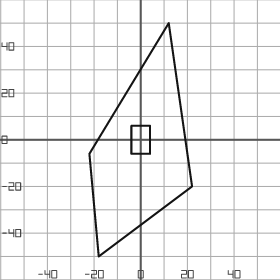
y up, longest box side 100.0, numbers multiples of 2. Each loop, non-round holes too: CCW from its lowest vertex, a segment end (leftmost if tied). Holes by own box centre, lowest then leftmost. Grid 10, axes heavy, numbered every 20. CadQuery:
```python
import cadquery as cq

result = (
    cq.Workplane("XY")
    .moveTo(-18.0, -50.0)
    .lineTo(22.0, -20.0)
    .lineTo(12.0, 50.0)
    .lineTo(-22.0, -6.0)
    .close()
    .moveTo(-4.0, -6.0)
    .lineTo(4.0, -6.0)
    .lineTo(4.0, 6.0)
    .lineTo(-4.0, 6.0)
    .close()
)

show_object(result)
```